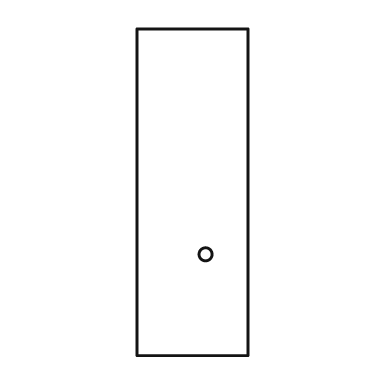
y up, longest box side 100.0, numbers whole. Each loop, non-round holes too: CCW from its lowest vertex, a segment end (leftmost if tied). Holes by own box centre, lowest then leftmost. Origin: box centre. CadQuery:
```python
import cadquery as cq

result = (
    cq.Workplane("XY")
    .moveTo(-17.0, -50.0)
    .lineTo(17.0, -50.0)
    .lineTo(17.0, 50.0)
    .lineTo(-17.0, 50.0)
    .close()
    .moveTo(4.0, -19.0)
    .circle(2.0)
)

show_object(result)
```